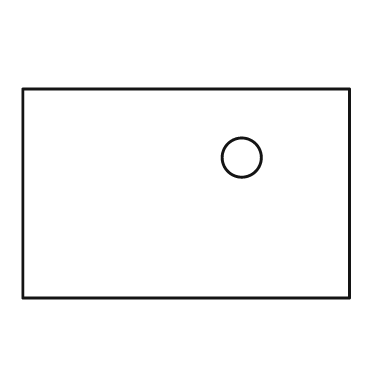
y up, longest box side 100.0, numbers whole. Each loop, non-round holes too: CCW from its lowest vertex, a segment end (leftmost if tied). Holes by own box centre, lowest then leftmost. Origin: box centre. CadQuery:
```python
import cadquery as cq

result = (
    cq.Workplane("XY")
    .moveTo(-50.0, -32.0)
    .lineTo(50.0, -32.0)
    .lineTo(50.0, 32.0)
    .lineTo(-50.0, 32.0)
    .close()
    .moveTo(17.0, 11.0)
    .circle(6.0)
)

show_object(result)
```